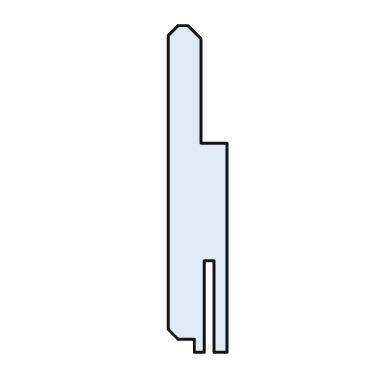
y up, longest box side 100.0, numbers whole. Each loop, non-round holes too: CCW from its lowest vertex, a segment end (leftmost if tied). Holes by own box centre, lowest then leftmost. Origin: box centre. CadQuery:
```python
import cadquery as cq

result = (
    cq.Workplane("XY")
    .moveTo(-1.0, -50.0)
    .lineTo(2.0, -50.0)
    .lineTo(2.0, -22.0)
    .lineTo(5.0, -22.0)
    .lineTo(5.0, -50.0)
    .lineTo(9.0, -50.0)
    .lineTo(9.0, 14.0)
    .lineTo(1.0, 14.0)
    .lineTo(1.0, 46.0)
    .lineTo(-3.0, 50.0)
    .lineTo(-6.0, 50.0)
    .lineTo(-9.0, 47.0)
    .lineTo(-9.0, -43.0)
    .lineTo(-6.0, -46.0)
    .lineTo(-1.0, -46.0)
    .close()
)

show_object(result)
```